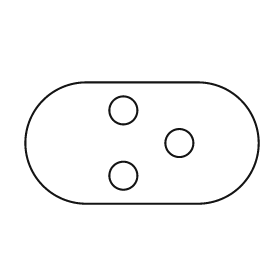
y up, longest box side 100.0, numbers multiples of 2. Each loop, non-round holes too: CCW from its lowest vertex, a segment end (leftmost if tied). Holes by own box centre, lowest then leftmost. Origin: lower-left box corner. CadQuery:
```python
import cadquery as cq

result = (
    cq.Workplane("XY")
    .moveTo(26.0, 0.0)
    .lineTo(74.0, 0.0)
    .threePointArc((100.0, 26.0), (74.0, 52.0))
    .lineTo(26.0, 52.0)
    .threePointArc((0.0, 26.0), (26.0, 0.0))
    .close()
    .moveTo(42.0, 12.0)
    .circle(6.0)
    .moveTo(66.0, 26.0)
    .circle(6.0)
    .moveTo(42.0, 40.0)
    .circle(6.0)
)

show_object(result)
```